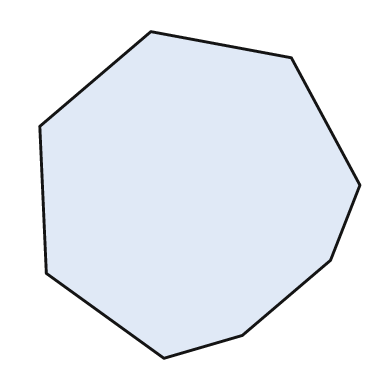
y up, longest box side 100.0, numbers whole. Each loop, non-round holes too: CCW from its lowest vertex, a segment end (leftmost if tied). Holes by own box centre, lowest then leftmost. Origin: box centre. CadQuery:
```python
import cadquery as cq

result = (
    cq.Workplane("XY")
    .moveTo(-11.0, -50.0)
    .lineTo(13.0, -43.0)
    .lineTo(40.0, -20.0)
    .lineTo(49.0, 3.0)
    .lineTo(28.0, 42.0)
    .lineTo(-15.0, 50.0)
    .lineTo(-49.0, 21.0)
    .lineTo(-47.0, -24.0)
    .close()
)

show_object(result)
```